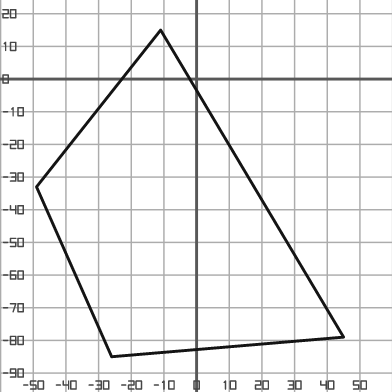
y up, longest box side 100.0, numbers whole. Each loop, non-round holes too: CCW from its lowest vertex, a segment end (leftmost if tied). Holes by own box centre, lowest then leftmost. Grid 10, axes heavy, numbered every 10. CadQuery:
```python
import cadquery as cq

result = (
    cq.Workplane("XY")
    .moveTo(-26.0, -85.0)
    .lineTo(45.0, -79.0)
    .lineTo(-11.0, 15.0)
    .lineTo(-49.0, -33.0)
    .close()
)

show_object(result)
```